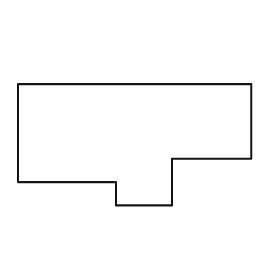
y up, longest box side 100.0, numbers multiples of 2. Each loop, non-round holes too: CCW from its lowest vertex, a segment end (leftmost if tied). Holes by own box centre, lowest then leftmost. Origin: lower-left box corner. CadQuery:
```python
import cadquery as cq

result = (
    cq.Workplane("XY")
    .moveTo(42.0, 0.0)
    .lineTo(66.0, 0.0)
    .lineTo(66.0, 20.0)
    .lineTo(100.0, 20.0)
    .lineTo(100.0, 52.0)
    .lineTo(0.0, 52.0)
    .lineTo(0.0, 10.0)
    .lineTo(42.0, 10.0)
    .close()
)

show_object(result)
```